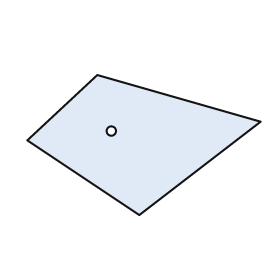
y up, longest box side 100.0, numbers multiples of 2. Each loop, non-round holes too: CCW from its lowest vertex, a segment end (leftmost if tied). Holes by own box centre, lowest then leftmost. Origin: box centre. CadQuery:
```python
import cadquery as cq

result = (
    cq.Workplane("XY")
    .moveTo(-2.0, -30.0)
    .lineTo(50.0, 10.0)
    .lineTo(-20.0, 30.0)
    .lineTo(-50.0, 2.0)
    .close()
    .moveTo(-14.0, 6.0)
    .circle(2.0)
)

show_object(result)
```